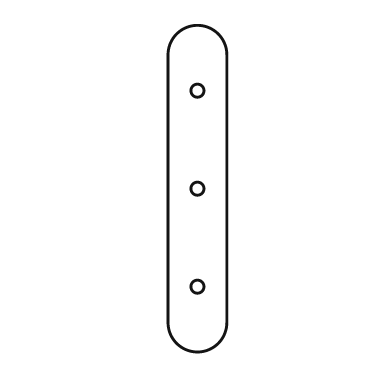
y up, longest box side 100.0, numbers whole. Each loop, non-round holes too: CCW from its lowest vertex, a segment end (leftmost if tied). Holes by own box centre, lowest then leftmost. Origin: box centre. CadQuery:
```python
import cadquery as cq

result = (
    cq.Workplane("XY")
    .moveTo(-9.0, -41.0)
    .threePointArc((0.0, -50.0), (9.0, -41.0))
    .lineTo(9.0, 41.0)
    .threePointArc((0.0, 50.0), (-9.0, 41.0))
    .close()
    .moveTo(0.0, -30.0)
    .circle(2.0)
    .moveTo(0.0, 0.0)
    .circle(2.0)
    .moveTo(0.0, 30.0)
    .circle(2.0)
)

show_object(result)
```